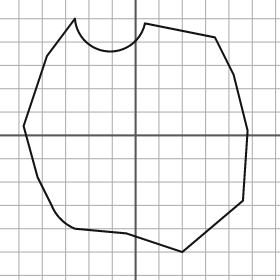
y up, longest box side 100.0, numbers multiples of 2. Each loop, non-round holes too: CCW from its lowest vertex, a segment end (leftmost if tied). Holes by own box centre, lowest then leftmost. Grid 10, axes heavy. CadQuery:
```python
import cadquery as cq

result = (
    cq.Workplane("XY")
    .moveTo(20.0, -50.0)
    .lineTo(46.0, -28.0)
    .lineTo(48.0, 2.0)
    .lineTo(42.0, 26.0)
    .lineTo(34.0, 42.0)
    .lineTo(4.0, 48.0)
    .threePointArc((-12.0, 36.0), (-26.0, 50.0))
    .lineTo(-38.0, 34.0)
    .lineTo(-48.0, 4.0)
    .lineTo(-42.0, -18.0)
    .lineTo(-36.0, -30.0)
    .threePointArc((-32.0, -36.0), (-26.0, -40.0))
    .lineTo(-4.0, -42.0)
    .close()
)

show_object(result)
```